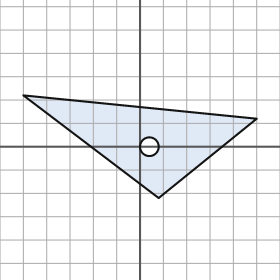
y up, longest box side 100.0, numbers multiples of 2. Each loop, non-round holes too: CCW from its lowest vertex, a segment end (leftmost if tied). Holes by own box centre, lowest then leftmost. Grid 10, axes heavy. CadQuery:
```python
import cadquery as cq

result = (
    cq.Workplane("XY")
    .moveTo(8.0, -22.0)
    .lineTo(50.0, 12.0)
    .lineTo(-50.0, 22.0)
    .close()
    .moveTo(4.0, 0.0)
    .circle(4.0)
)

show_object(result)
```